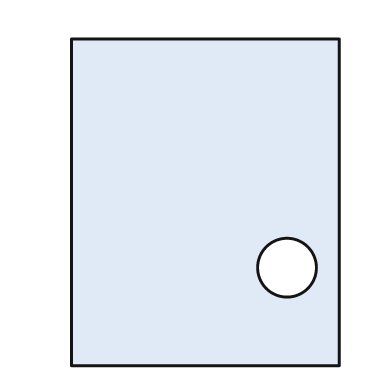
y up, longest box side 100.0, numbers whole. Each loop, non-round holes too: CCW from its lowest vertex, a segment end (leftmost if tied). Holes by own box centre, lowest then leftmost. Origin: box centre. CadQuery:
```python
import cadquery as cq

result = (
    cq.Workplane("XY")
    .moveTo(-41.0, -50.0)
    .lineTo(41.0, -50.0)
    .lineTo(41.0, 50.0)
    .lineTo(-41.0, 50.0)
    .close()
    .moveTo(25.0, -20.0)
    .circle(9.0)
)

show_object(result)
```